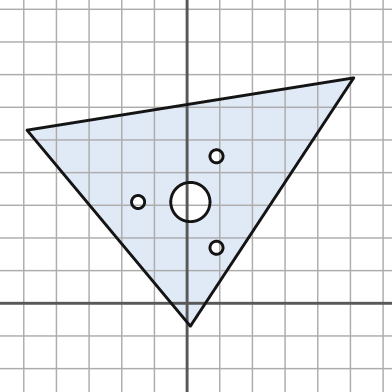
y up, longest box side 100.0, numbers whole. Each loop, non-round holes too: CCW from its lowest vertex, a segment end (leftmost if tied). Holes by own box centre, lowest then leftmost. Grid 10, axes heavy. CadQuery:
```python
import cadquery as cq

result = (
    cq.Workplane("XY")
    .moveTo(1.0, -7.0)
    .lineTo(51.0, 69.0)
    .lineTo(-49.0, 53.0)
    .close()
    .moveTo(9.0, 17.0)
    .circle(2.0)
    .moveTo(-15.0, 31.0)
    .circle(2.0)
    .moveTo(1.0, 31.0)
    .circle(6.0)
    .moveTo(9.0, 45.0)
    .circle(2.0)
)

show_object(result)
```